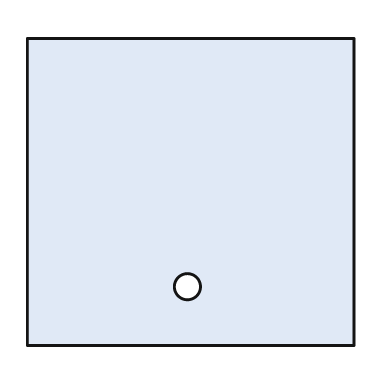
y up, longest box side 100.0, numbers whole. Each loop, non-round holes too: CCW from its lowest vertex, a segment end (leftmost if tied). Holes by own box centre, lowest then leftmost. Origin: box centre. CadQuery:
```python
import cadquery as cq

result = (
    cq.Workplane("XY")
    .moveTo(-50.0, -47.0)
    .lineTo(50.0, -47.0)
    .lineTo(50.0, 47.0)
    .lineTo(-50.0, 47.0)
    .close()
    .moveTo(-1.0, -29.0)
    .circle(4.0)
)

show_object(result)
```